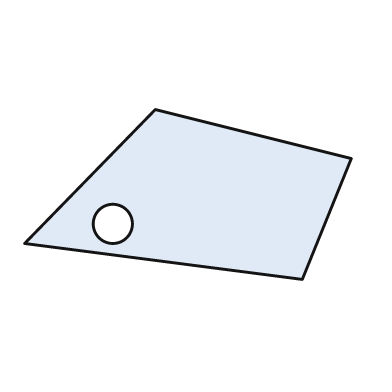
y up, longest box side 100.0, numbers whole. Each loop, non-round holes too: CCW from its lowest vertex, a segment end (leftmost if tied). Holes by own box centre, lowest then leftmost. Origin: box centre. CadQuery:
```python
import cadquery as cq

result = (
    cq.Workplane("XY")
    .moveTo(35.0, -26.0)
    .lineTo(50.0, 11.0)
    .lineTo(-10.0, 26.0)
    .lineTo(-50.0, -15.0)
    .close()
    .moveTo(-23.0, -9.0)
    .circle(6.0)
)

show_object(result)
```